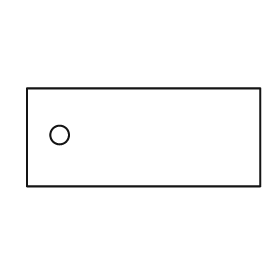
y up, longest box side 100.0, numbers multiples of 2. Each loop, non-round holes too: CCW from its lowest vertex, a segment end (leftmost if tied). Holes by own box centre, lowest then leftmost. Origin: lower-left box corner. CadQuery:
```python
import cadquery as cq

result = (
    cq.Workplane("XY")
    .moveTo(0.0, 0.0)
    .lineTo(100.0, 0.0)
    .lineTo(100.0, 42.0)
    .lineTo(0.0, 42.0)
    .close()
    .moveTo(14.0, 22.0)
    .circle(4.0)
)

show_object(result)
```